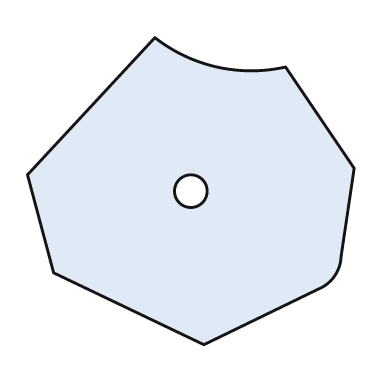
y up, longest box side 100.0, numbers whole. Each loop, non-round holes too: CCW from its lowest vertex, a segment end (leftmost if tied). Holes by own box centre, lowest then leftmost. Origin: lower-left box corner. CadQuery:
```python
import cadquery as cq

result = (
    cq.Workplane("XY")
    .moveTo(54.0, 0.0)
    .lineTo(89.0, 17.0)
    .threePointArc((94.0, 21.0), (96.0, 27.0))
    .lineTo(100.0, 54.0)
    .lineTo(79.0, 85.0)
    .threePointArc((58.0, 85.0), (39.0, 94.0))
    .lineTo(0.0, 52.0)
    .lineTo(8.0, 22.0)
    .close()
    .moveTo(50.0, 47.0)
    .circle(5.0)
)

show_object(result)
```